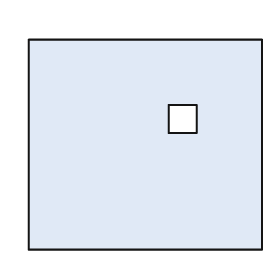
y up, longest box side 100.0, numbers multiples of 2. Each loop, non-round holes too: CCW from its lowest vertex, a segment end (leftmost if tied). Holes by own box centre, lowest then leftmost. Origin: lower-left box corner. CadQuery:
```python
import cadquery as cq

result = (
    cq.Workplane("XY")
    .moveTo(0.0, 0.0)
    .lineTo(100.0, 0.0)
    .lineTo(100.0, 90.0)
    .lineTo(0.0, 90.0)
    .close()
    .moveTo(60.0, 50.0)
    .lineTo(72.0, 50.0)
    .lineTo(72.0, 62.0)
    .lineTo(60.0, 62.0)
    .close()
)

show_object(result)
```